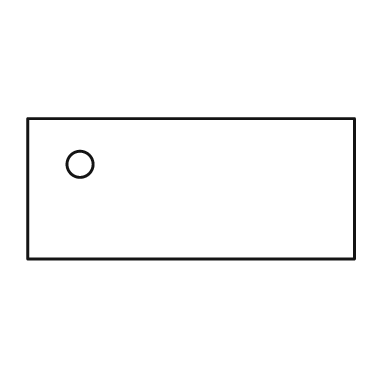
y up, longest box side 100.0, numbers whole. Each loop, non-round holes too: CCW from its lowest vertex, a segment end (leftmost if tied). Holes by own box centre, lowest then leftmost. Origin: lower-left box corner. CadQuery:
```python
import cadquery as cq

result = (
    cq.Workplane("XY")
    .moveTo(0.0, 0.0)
    .lineTo(100.0, 0.0)
    .lineTo(100.0, 43.0)
    .lineTo(0.0, 43.0)
    .close()
    .moveTo(16.0, 29.0)
    .circle(4.0)
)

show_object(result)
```